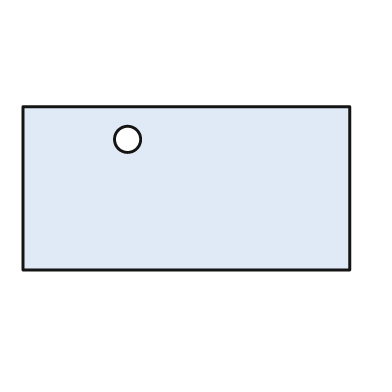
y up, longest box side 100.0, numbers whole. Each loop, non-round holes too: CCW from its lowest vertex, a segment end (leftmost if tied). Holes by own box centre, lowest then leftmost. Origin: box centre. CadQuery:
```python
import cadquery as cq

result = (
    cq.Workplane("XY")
    .moveTo(-50.0, -25.0)
    .lineTo(50.0, -25.0)
    .lineTo(50.0, 25.0)
    .lineTo(-50.0, 25.0)
    .close()
    .moveTo(-18.0, 15.0)
    .circle(4.0)
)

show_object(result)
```